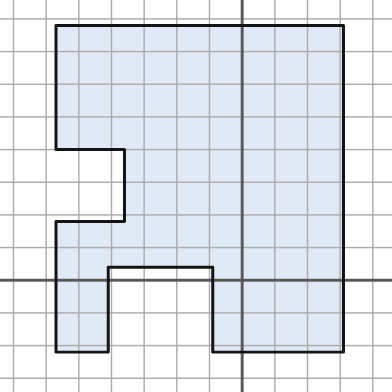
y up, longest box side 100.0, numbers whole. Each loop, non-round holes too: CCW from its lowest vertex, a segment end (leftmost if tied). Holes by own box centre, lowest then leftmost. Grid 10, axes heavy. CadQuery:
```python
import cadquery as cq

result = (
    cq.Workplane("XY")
    .moveTo(-57.0, -22.0)
    .lineTo(-41.0, -22.0)
    .lineTo(-41.0, 4.0)
    .lineTo(-9.0, 4.0)
    .lineTo(-9.0, -22.0)
    .lineTo(31.0, -22.0)
    .lineTo(31.0, 78.0)
    .lineTo(-57.0, 78.0)
    .lineTo(-57.0, 40.0)
    .lineTo(-36.0, 40.0)
    .lineTo(-36.0, 18.0)
    .lineTo(-57.0, 18.0)
    .close()
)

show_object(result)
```